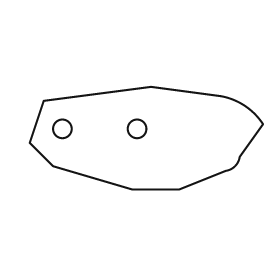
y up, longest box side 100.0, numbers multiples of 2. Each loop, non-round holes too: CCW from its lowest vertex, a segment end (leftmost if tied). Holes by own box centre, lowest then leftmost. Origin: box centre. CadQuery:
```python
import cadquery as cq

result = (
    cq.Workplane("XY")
    .moveTo(-6.0, -22.0)
    .lineTo(14.0, -22.0)
    .lineTo(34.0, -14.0)
    .threePointArc((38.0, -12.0), (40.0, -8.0))
    .lineTo(50.0, 6.0)
    .threePointArc((42.0, 14.0), (32.0, 18.0))
    .lineTo(2.0, 22.0)
    .lineTo(-44.0, 16.0)
    .lineTo(-50.0, -2.0)
    .lineTo(-40.0, -12.0)
    .close()
    .moveTo(-36.0, 4.0)
    .circle(4.0)
    .moveTo(-4.0, 4.0)
    .circle(4.0)
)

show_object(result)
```